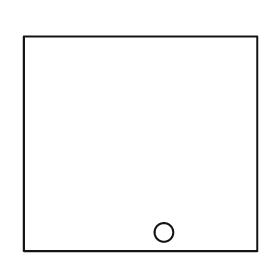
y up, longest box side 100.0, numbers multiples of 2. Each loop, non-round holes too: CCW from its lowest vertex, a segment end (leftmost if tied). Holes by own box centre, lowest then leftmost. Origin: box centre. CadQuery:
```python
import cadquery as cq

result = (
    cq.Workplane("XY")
    .moveTo(-50.0, -46.0)
    .lineTo(50.0, -46.0)
    .lineTo(50.0, 46.0)
    .lineTo(-50.0, 46.0)
    .close()
    .moveTo(10.0, -38.0)
    .circle(4.0)
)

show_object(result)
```